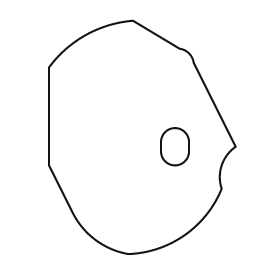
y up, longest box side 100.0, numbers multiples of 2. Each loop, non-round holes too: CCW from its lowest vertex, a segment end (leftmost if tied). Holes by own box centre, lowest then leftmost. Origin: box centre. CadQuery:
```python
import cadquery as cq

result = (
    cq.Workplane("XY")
    .moveTo(-6.0, -50.0)
    .threePointArc((18.0, -42.0), (34.0, -22.0))
    .threePointArc((34.0, -12.0), (40.0, -4.0))
    .lineTo(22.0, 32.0)
    .threePointArc((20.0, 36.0), (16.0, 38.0))
    .lineTo(-4.0, 50.0)
    .threePointArc((-24.0, 44.0), (-40.0, 30.0))
    .lineTo(-40.0, -12.0)
    .lineTo(-30.0, -32.0)
    .threePointArc((-20.0, -44.0), (-6.0, -50.0))
    .close()
    .moveTo(8.0, -6.0)
    .threePointArc((14.0, -12.0), (20.0, -6.0))
    .lineTo(20.0, -2.0)
    .threePointArc((14.0, 4.0), (8.0, -2.0))
    .close()
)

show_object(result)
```